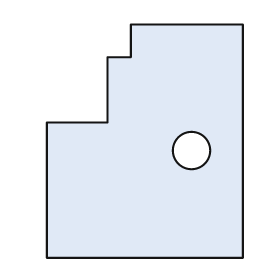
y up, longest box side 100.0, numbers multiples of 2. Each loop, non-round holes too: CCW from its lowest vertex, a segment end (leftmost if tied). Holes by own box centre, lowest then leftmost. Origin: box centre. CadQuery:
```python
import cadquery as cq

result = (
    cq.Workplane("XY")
    .moveTo(-42.0, -50.0)
    .lineTo(42.0, -50.0)
    .lineTo(42.0, 50.0)
    .lineTo(-6.0, 50.0)
    .lineTo(-6.0, 36.0)
    .lineTo(-16.0, 36.0)
    .lineTo(-16.0, 8.0)
    .lineTo(-42.0, 8.0)
    .close()
    .moveTo(20.0, -4.0)
    .circle(8.0)
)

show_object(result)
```